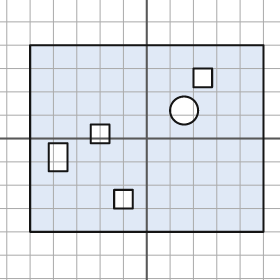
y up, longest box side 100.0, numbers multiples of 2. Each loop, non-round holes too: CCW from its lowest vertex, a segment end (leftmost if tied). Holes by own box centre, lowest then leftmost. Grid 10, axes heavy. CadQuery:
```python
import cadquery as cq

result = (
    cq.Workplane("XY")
    .moveTo(-50.0, -40.0)
    .lineTo(50.0, -40.0)
    .lineTo(50.0, 40.0)
    .lineTo(-50.0, 40.0)
    .close()
    .moveTo(-14.0, -30.0)
    .lineTo(-6.0, -30.0)
    .lineTo(-6.0, -22.0)
    .lineTo(-14.0, -22.0)
    .close()
    .moveTo(-42.0, -14.0)
    .lineTo(-34.0, -14.0)
    .lineTo(-34.0, -2.0)
    .lineTo(-42.0, -2.0)
    .close()
    .moveTo(-24.0, -2.0)
    .lineTo(-16.0, -2.0)
    .lineTo(-16.0, 6.0)
    .lineTo(-24.0, 6.0)
    .close()
    .moveTo(16.0, 12.0)
    .circle(6.0)
    .moveTo(20.0, 22.0)
    .lineTo(28.0, 22.0)
    .lineTo(28.0, 30.0)
    .lineTo(20.0, 30.0)
    .close()
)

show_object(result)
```